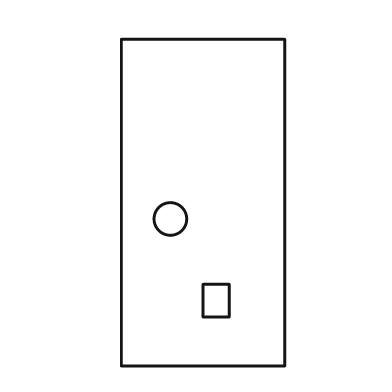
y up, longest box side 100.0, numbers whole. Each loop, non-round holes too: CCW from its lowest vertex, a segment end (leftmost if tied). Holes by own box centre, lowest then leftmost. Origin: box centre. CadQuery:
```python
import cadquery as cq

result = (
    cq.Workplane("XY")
    .moveTo(-25.0, -50.0)
    .lineTo(25.0, -50.0)
    .lineTo(25.0, 50.0)
    .lineTo(-25.0, 50.0)
    .close()
    .moveTo(0.0, -35.0)
    .lineTo(8.0, -35.0)
    .lineTo(8.0, -25.0)
    .lineTo(0.0, -25.0)
    .close()
    .moveTo(-10.0, -5.0)
    .circle(5.0)
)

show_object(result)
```